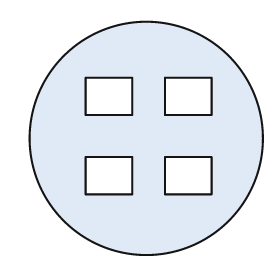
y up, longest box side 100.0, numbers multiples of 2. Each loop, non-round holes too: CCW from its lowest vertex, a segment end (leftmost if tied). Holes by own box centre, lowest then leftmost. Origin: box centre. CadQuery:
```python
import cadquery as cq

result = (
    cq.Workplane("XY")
    .moveTo(0.0, 0.0)
    .circle(50.0)
    .moveTo(-26.0, -24.0)
    .lineTo(-6.0, -24.0)
    .lineTo(-6.0, -8.0)
    .lineTo(-26.0, -8.0)
    .close()
    .moveTo(8.0, -24.0)
    .lineTo(28.0, -24.0)
    .lineTo(28.0, -8.0)
    .lineTo(8.0, -8.0)
    .close()
    .moveTo(-26.0, 10.0)
    .lineTo(-6.0, 10.0)
    .lineTo(-6.0, 26.0)
    .lineTo(-26.0, 26.0)
    .close()
    .moveTo(8.0, 10.0)
    .lineTo(28.0, 10.0)
    .lineTo(28.0, 26.0)
    .lineTo(8.0, 26.0)
    .close()
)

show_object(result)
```